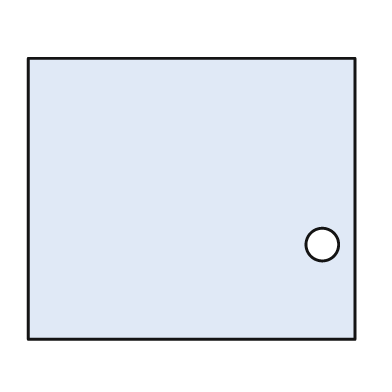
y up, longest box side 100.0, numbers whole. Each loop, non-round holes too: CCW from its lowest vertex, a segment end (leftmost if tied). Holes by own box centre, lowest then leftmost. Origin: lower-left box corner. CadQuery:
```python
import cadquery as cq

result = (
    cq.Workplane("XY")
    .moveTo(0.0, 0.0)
    .lineTo(100.0, 0.0)
    .lineTo(100.0, 86.0)
    .lineTo(0.0, 86.0)
    .close()
    .moveTo(90.0, 29.0)
    .circle(5.0)
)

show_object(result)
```